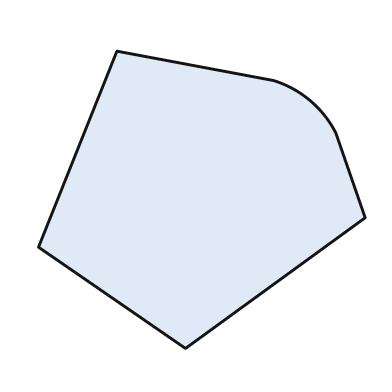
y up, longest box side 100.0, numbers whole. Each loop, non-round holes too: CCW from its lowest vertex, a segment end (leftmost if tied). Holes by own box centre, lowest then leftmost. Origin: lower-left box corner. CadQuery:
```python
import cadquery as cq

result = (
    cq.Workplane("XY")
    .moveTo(45.0, 0.0)
    .lineTo(100.0, 40.0)
    .lineTo(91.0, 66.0)
    .threePointArc((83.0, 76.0), (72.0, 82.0))
    .lineTo(24.0, 91.0)
    .lineTo(0.0, 31.0)
    .close()
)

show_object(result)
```